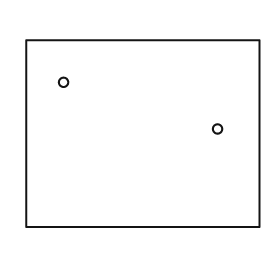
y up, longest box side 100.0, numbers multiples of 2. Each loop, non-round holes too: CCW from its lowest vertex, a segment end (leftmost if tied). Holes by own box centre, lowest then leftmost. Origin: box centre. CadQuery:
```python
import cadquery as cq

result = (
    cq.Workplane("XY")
    .moveTo(-50.0, -40.0)
    .lineTo(50.0, -40.0)
    .lineTo(50.0, 40.0)
    .lineTo(-50.0, 40.0)
    .close()
    .moveTo(32.0, 2.0)
    .circle(2.0)
    .moveTo(-34.0, 22.0)
    .circle(2.0)
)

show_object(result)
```